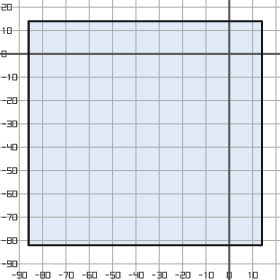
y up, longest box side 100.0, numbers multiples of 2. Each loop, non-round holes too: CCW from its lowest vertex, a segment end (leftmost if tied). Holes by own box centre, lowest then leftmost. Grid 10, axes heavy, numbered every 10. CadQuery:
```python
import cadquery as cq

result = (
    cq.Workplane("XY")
    .moveTo(-86.0, -82.0)
    .lineTo(14.0, -82.0)
    .lineTo(14.0, 14.0)
    .lineTo(-86.0, 14.0)
    .close()
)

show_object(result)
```